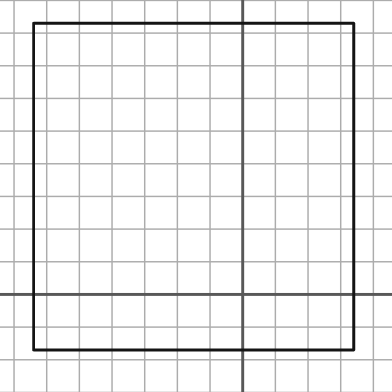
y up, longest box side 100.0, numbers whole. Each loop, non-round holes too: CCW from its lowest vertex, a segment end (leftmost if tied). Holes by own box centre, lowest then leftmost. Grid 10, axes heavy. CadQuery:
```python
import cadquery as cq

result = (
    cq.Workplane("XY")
    .moveTo(-64.0, -17.0)
    .lineTo(34.0, -17.0)
    .lineTo(34.0, 83.0)
    .lineTo(-64.0, 83.0)
    .close()
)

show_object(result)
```